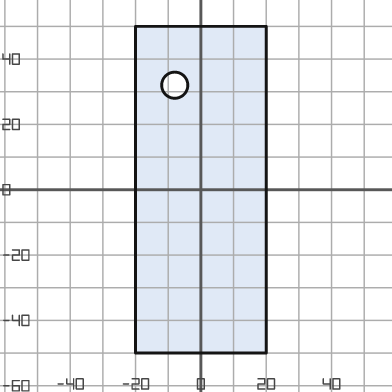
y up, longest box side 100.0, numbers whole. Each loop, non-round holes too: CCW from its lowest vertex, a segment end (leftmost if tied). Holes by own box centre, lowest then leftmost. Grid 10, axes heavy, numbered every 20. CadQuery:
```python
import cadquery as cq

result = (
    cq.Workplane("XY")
    .moveTo(-20.0, -50.0)
    .lineTo(20.0, -50.0)
    .lineTo(20.0, 50.0)
    .lineTo(-20.0, 50.0)
    .close()
    .moveTo(-8.0, 32.0)
    .circle(4.0)
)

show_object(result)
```